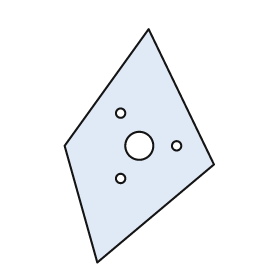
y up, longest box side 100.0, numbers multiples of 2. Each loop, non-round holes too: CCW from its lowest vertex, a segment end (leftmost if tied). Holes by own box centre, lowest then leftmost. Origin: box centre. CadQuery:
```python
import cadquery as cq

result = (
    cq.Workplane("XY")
    .moveTo(-18.0, -50.0)
    .lineTo(32.0, -8.0)
    .lineTo(4.0, 50.0)
    .lineTo(-32.0, 0.0)
    .close()
    .moveTo(-8.0, -14.0)
    .circle(2.0)
    .moveTo(0.0, 0.0)
    .circle(6.0)
    .moveTo(16.0, 0.0)
    .circle(2.0)
    .moveTo(-8.0, 14.0)
    .circle(2.0)
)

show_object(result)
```